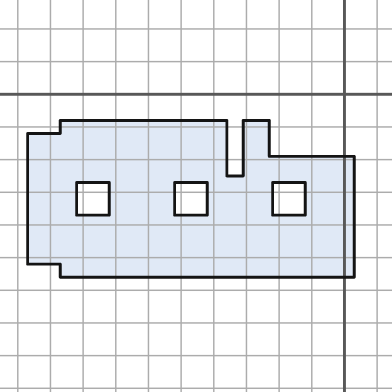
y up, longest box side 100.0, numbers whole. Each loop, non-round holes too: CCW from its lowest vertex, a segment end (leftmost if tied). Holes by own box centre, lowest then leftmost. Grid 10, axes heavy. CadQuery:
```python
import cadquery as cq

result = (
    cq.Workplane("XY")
    .moveTo(-87.0, -56.0)
    .lineTo(3.0, -56.0)
    .lineTo(3.0, -19.0)
    .lineTo(-23.0, -19.0)
    .lineTo(-23.0, -8.0)
    .lineTo(-31.0, -8.0)
    .lineTo(-31.0, -25.0)
    .lineTo(-36.0, -25.0)
    .lineTo(-36.0, -8.0)
    .lineTo(-87.0, -8.0)
    .lineTo(-87.0, -12.0)
    .lineTo(-97.0, -12.0)
    .lineTo(-97.0, -52.0)
    .lineTo(-87.0, -52.0)
    .close()
    .moveTo(-82.0, -37.0)
    .lineTo(-72.0, -37.0)
    .lineTo(-72.0, -27.0)
    .lineTo(-82.0, -27.0)
    .close()
    .moveTo(-52.0, -37.0)
    .lineTo(-42.0, -37.0)
    .lineTo(-42.0, -27.0)
    .lineTo(-52.0, -27.0)
    .close()
    .moveTo(-22.0, -37.0)
    .lineTo(-12.0, -37.0)
    .lineTo(-12.0, -27.0)
    .lineTo(-22.0, -27.0)
    .close()
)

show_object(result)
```